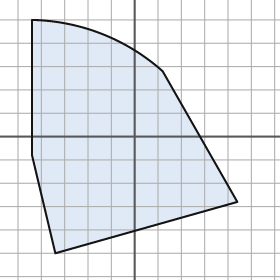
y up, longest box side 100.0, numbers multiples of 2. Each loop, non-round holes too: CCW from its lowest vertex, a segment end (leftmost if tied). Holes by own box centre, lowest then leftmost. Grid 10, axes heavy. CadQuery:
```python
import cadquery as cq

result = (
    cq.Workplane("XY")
    .moveTo(-34.0, -50.0)
    .lineTo(44.0, -28.0)
    .lineTo(12.0, 28.0)
    .threePointArc((-14.0, 44.0), (-44.0, 50.0))
    .lineTo(-44.0, -8.0)
    .close()
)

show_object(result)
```